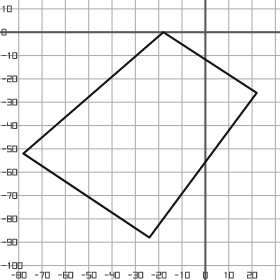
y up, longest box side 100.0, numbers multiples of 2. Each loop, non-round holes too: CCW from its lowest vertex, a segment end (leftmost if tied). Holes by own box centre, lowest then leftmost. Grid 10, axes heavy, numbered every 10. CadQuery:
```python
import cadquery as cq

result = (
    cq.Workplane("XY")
    .moveTo(-24.0, -88.0)
    .lineTo(22.0, -26.0)
    .lineTo(-18.0, 0.0)
    .lineTo(-78.0, -52.0)
    .close()
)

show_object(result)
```